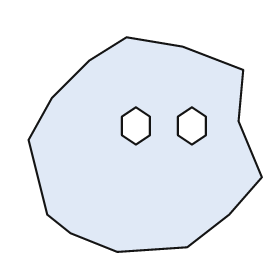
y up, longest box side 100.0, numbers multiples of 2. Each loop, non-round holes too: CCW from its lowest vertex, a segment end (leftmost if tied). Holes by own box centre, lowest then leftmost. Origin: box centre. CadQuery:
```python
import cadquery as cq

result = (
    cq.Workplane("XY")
    .moveTo(-12.0, -46.0)
    .lineTo(18.0, -44.0)
    .lineTo(36.0, -30.0)
    .lineTo(50.0, -14.0)
    .lineTo(40.0, 10.0)
    .lineTo(42.0, 32.0)
    .lineTo(16.0, 42.0)
    .lineTo(-8.0, 46.0)
    .lineTo(-24.0, 36.0)
    .lineTo(-40.0, 20.0)
    .lineTo(-50.0, 2.0)
    .lineTo(-42.0, -30.0)
    .lineTo(-32.0, -38.0)
    .close()
    .moveTo(-4.0, 0.0)
    .lineTo(2.0, 4.0)
    .lineTo(2.0, 12.0)
    .lineTo(-4.0, 16.0)
    .lineTo(-10.0, 12.0)
    .lineTo(-10.0, 4.0)
    .close()
    .moveTo(20.0, 0.0)
    .lineTo(26.0, 4.0)
    .lineTo(26.0, 12.0)
    .lineTo(20.0, 16.0)
    .lineTo(14.0, 12.0)
    .lineTo(14.0, 4.0)
    .close()
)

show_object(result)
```